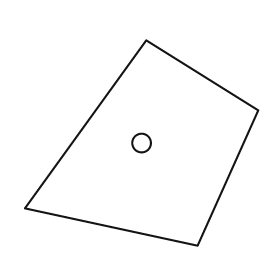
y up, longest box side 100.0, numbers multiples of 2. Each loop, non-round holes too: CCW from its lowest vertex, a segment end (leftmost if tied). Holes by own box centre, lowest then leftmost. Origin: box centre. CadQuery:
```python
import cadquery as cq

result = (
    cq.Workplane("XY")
    .moveTo(24.0, -44.0)
    .lineTo(50.0, 14.0)
    .lineTo(2.0, 44.0)
    .lineTo(-50.0, -28.0)
    .close()
    .moveTo(0.0, 0.0)
    .circle(4.0)
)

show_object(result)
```